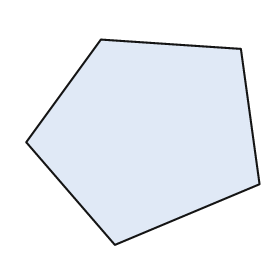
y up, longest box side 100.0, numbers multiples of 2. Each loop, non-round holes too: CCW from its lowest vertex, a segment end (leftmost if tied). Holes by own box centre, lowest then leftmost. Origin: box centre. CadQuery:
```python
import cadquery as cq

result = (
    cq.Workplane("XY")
    .moveTo(-12.0, -44.0)
    .lineTo(50.0, -18.0)
    .lineTo(42.0, 40.0)
    .lineTo(-18.0, 44.0)
    .lineTo(-50.0, 0.0)
    .close()
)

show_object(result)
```